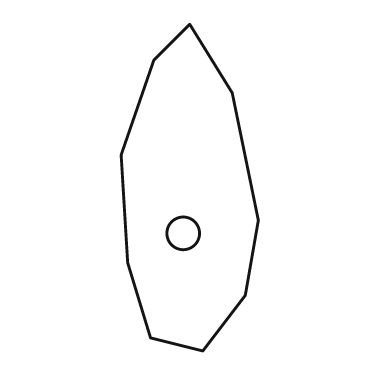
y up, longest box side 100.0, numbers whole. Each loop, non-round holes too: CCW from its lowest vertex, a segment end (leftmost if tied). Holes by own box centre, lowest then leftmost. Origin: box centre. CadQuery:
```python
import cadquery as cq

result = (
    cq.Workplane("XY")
    .moveTo(4.0, -50.0)
    .lineTo(17.0, -33.0)
    .lineTo(21.0, -10.0)
    .lineTo(13.0, 29.0)
    .lineTo(0.0, 50.0)
    .lineTo(-11.0, 39.0)
    .lineTo(-21.0, 10.0)
    .lineTo(-19.0, -23.0)
    .lineTo(-12.0, -46.0)
    .close()
    .moveTo(-2.0, -14.0)
    .circle(5.0)
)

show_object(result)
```